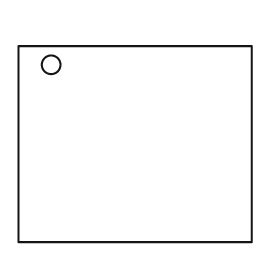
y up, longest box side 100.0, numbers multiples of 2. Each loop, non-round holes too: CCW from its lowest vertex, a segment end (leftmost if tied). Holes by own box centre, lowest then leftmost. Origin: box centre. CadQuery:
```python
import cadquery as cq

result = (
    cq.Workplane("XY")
    .moveTo(-50.0, -42.0)
    .lineTo(50.0, -42.0)
    .lineTo(50.0, 42.0)
    .lineTo(-50.0, 42.0)
    .close()
    .moveTo(-36.0, 34.0)
    .circle(4.0)
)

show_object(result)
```